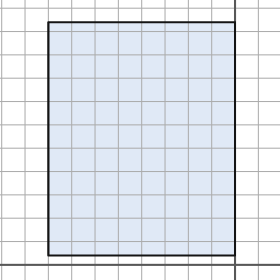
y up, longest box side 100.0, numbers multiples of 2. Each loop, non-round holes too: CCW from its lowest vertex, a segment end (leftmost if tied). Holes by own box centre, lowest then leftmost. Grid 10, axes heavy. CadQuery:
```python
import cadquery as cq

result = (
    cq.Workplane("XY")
    .moveTo(-80.0, 4.0)
    .lineTo(0.0, 4.0)
    .lineTo(0.0, 104.0)
    .lineTo(-80.0, 104.0)
    .close()
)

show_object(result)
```